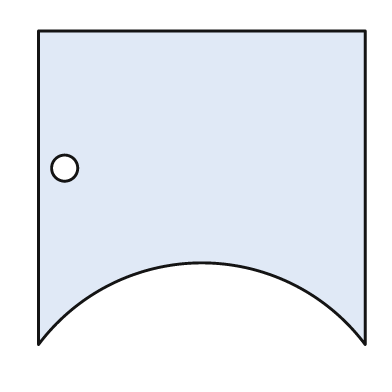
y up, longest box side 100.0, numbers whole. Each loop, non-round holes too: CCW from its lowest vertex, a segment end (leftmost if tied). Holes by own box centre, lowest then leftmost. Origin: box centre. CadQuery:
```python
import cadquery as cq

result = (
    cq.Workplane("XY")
    .moveTo(-50.0, -48.0)
    .threePointArc((0.0, -23.0), (50.0, -48.0))
    .lineTo(50.0, 48.0)
    .lineTo(-50.0, 48.0)
    .close()
    .moveTo(-42.0, 6.0)
    .circle(4.0)
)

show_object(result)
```